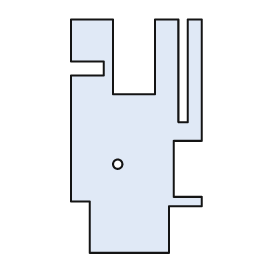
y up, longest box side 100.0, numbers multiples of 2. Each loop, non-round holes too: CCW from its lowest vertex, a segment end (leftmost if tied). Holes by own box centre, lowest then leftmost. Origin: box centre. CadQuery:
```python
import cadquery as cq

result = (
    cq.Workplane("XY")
    .moveTo(-20.0, -50.0)
    .lineTo(14.0, -50.0)
    .lineTo(14.0, -30.0)
    .lineTo(28.0, -30.0)
    .lineTo(28.0, -26.0)
    .lineTo(16.0, -26.0)
    .lineTo(16.0, -2.0)
    .lineTo(28.0, -2.0)
    .lineTo(28.0, 50.0)
    .lineTo(22.0, 50.0)
    .lineTo(22.0, 6.0)
    .lineTo(18.0, 6.0)
    .lineTo(18.0, 50.0)
    .lineTo(8.0, 50.0)
    .lineTo(8.0, 18.0)
    .lineTo(-10.0, 18.0)
    .lineTo(-10.0, 50.0)
    .lineTo(-28.0, 50.0)
    .lineTo(-28.0, 32.0)
    .lineTo(-14.0, 32.0)
    .lineTo(-14.0, 26.0)
    .lineTo(-28.0, 26.0)
    .lineTo(-28.0, -28.0)
    .lineTo(-20.0, -28.0)
    .close()
    .moveTo(-8.0, -12.0)
    .circle(2.0)
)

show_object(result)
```